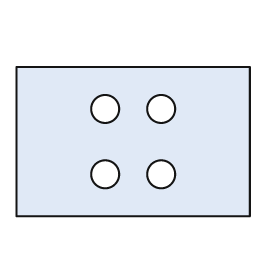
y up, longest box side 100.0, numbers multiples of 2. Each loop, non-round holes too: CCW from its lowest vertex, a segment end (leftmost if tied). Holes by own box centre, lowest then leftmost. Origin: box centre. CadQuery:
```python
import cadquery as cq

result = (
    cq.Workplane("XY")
    .moveTo(-50.0, -32.0)
    .lineTo(50.0, -32.0)
    .lineTo(50.0, 32.0)
    .lineTo(-50.0, 32.0)
    .close()
    .moveTo(-12.0, -14.0)
    .circle(6.0)
    .moveTo(12.0, -14.0)
    .circle(6.0)
    .moveTo(-12.0, 14.0)
    .circle(6.0)
    .moveTo(12.0, 14.0)
    .circle(6.0)
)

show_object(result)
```